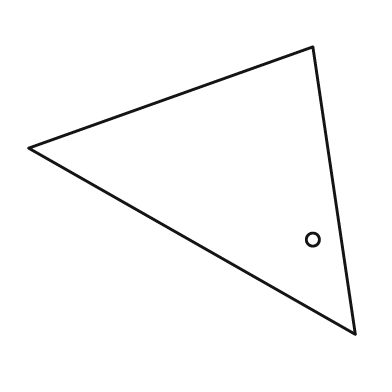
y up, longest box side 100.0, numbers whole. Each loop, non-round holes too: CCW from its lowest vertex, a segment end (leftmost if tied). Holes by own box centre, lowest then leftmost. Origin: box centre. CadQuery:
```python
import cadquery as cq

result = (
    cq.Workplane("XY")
    .moveTo(50.0, -44.0)
    .lineTo(37.0, 44.0)
    .lineTo(-50.0, 13.0)
    .close()
    .moveTo(37.0, -15.0)
    .circle(2.0)
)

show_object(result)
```